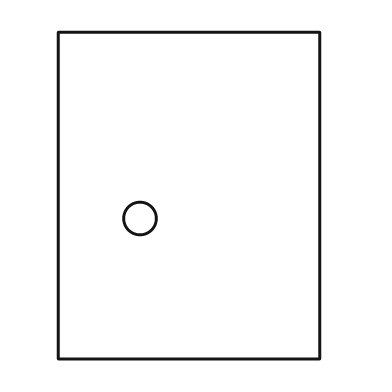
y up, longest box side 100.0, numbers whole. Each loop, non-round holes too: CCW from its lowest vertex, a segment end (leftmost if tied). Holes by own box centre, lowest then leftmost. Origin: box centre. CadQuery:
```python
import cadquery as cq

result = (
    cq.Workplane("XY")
    .moveTo(-40.0, -50.0)
    .lineTo(40.0, -50.0)
    .lineTo(40.0, 50.0)
    .lineTo(-40.0, 50.0)
    .close()
    .moveTo(-15.0, -7.0)
    .circle(5.0)
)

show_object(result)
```